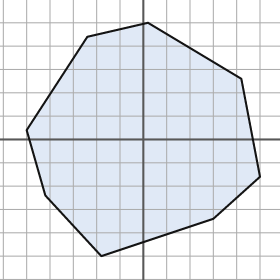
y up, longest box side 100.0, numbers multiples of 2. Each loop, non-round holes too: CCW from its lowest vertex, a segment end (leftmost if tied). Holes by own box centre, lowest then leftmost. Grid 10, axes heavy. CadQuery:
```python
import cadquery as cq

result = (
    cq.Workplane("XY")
    .moveTo(-18.0, -50.0)
    .lineTo(30.0, -34.0)
    .lineTo(50.0, -16.0)
    .lineTo(42.0, 26.0)
    .lineTo(2.0, 50.0)
    .lineTo(-24.0, 44.0)
    .lineTo(-50.0, 4.0)
    .lineTo(-42.0, -24.0)
    .close()
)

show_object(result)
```